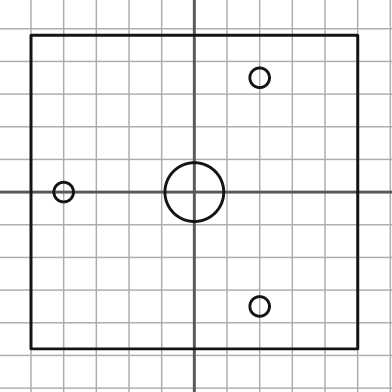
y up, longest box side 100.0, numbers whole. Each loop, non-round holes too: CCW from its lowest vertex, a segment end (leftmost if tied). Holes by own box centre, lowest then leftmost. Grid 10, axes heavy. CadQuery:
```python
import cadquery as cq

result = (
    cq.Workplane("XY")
    .moveTo(-50.0, -48.0)
    .lineTo(50.0, -48.0)
    .lineTo(50.0, 48.0)
    .lineTo(-50.0, 48.0)
    .close()
    .moveTo(20.0, -35.0)
    .circle(3.0)
    .moveTo(-40.0, 0.0)
    .circle(3.0)
    .moveTo(0.0, 0.0)
    .circle(9.0)
    .moveTo(20.0, 35.0)
    .circle(3.0)
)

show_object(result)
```